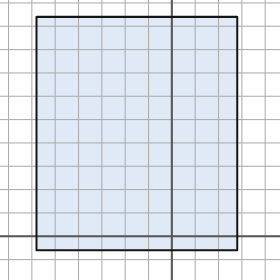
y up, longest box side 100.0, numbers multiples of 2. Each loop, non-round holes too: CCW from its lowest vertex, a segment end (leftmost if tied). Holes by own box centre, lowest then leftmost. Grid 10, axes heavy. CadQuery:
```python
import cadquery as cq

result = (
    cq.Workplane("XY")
    .moveTo(-58.0, -6.0)
    .lineTo(28.0, -6.0)
    .lineTo(28.0, 94.0)
    .lineTo(-58.0, 94.0)
    .close()
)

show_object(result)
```